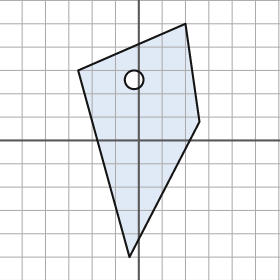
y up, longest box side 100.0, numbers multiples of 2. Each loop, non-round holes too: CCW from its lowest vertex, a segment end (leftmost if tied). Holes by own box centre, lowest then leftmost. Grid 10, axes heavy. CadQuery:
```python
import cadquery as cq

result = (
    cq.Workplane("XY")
    .moveTo(-4.0, -50.0)
    .lineTo(26.0, 8.0)
    .lineTo(20.0, 50.0)
    .lineTo(-26.0, 30.0)
    .close()
    .moveTo(-2.0, 26.0)
    .circle(4.0)
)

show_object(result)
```